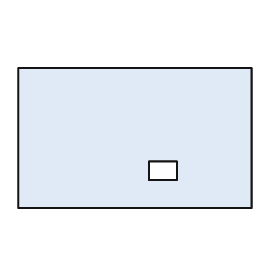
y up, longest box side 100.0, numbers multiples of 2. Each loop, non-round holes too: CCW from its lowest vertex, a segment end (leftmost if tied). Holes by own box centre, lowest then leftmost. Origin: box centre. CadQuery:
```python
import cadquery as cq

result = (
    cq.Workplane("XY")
    .moveTo(-50.0, -30.0)
    .lineTo(50.0, -30.0)
    .lineTo(50.0, 30.0)
    .lineTo(-50.0, 30.0)
    .close()
    .moveTo(6.0, -18.0)
    .lineTo(18.0, -18.0)
    .lineTo(18.0, -10.0)
    .lineTo(6.0, -10.0)
    .close()
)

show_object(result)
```